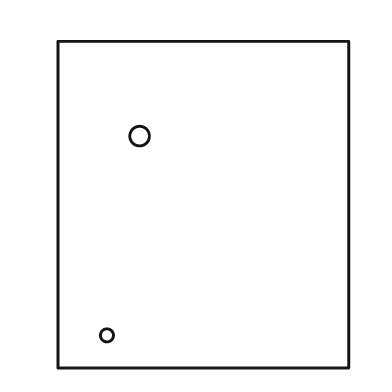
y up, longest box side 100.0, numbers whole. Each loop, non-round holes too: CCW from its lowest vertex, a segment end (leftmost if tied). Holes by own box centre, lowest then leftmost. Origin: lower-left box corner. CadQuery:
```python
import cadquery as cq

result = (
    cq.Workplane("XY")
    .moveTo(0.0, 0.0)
    .lineTo(89.0, 0.0)
    .lineTo(89.0, 100.0)
    .lineTo(0.0, 100.0)
    .close()
    .moveTo(15.0, 10.0)
    .circle(2.0)
    .moveTo(25.0, 71.0)
    .circle(3.0)
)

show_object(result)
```